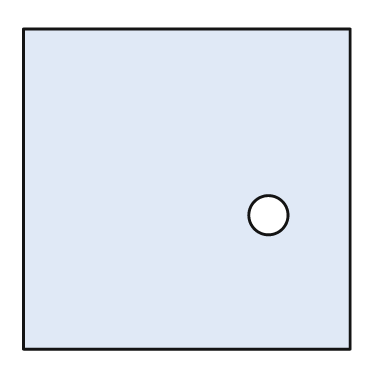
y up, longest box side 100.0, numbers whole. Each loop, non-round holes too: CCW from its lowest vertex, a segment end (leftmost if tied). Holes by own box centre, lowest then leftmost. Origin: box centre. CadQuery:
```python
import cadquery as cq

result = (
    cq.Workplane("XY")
    .moveTo(-50.0, -49.0)
    .lineTo(50.0, -49.0)
    .lineTo(50.0, 49.0)
    .lineTo(-50.0, 49.0)
    .close()
    .moveTo(25.0, -8.0)
    .circle(6.0)
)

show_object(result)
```